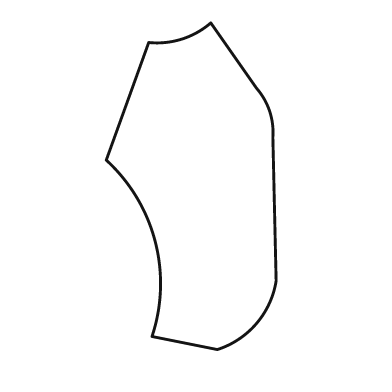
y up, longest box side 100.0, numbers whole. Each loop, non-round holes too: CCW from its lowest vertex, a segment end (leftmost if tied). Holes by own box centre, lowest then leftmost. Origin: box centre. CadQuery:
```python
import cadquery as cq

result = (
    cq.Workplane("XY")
    .moveTo(8.0, -50.0)
    .threePointArc((20.0, -42.0), (26.0, -29.0))
    .lineTo(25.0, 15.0)
    .threePointArc((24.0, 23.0), (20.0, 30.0))
    .lineTo(6.0, 50.0)
    .threePointArc((-3.0, 45.0), (-13.0, 44.0))
    .lineTo(-26.0, 8.0)
    .threePointArc((-11.0, -17.0), (-12.0, -46.0))
    .close()
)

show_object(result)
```